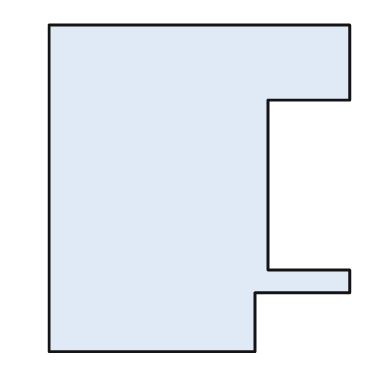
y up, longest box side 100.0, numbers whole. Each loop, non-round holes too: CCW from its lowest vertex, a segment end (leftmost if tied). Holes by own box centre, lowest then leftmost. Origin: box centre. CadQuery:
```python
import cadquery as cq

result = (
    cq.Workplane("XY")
    .moveTo(-46.0, -50.0)
    .lineTo(17.0, -50.0)
    .lineTo(17.0, -32.0)
    .lineTo(46.0, -32.0)
    .lineTo(46.0, -25.0)
    .lineTo(21.0, -25.0)
    .lineTo(21.0, 27.0)
    .lineTo(46.0, 27.0)
    .lineTo(46.0, 50.0)
    .lineTo(-46.0, 50.0)
    .close()
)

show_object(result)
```